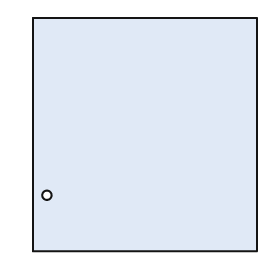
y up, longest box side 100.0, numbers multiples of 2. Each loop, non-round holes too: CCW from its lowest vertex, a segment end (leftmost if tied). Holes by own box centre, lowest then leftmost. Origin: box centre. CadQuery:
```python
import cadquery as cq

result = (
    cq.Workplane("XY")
    .moveTo(-48.0, -50.0)
    .lineTo(48.0, -50.0)
    .lineTo(48.0, 50.0)
    .lineTo(-48.0, 50.0)
    .close()
    .moveTo(-42.0, -26.0)
    .circle(2.0)
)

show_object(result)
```